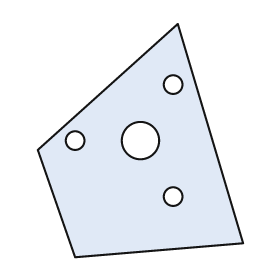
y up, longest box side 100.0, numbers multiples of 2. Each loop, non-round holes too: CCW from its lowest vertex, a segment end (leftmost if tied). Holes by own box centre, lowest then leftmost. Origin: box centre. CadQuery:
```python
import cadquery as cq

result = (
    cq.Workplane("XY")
    .moveTo(-28.0, -50.0)
    .lineTo(44.0, -44.0)
    .lineTo(16.0, 50.0)
    .lineTo(-44.0, -4.0)
    .close()
    .moveTo(14.0, -24.0)
    .circle(4.0)
    .moveTo(-28.0, 0.0)
    .circle(4.0)
    .moveTo(0.0, 0.0)
    .circle(8.0)
    .moveTo(14.0, 24.0)
    .circle(4.0)
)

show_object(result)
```